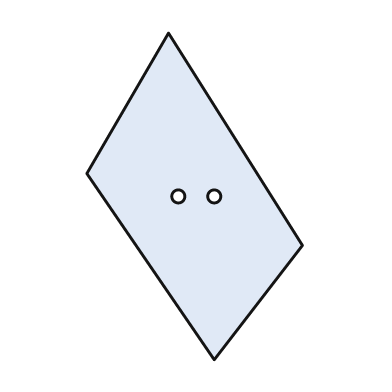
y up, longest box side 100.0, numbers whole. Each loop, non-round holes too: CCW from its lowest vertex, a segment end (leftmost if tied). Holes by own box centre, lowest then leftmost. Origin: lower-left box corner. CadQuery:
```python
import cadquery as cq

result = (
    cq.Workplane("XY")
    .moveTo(39.0, 0.0)
    .lineTo(66.0, 35.0)
    .lineTo(25.0, 100.0)
    .lineTo(0.0, 57.0)
    .close()
    .moveTo(28.0, 50.0)
    .circle(2.0)
    .moveTo(39.0, 50.0)
    .circle(2.0)
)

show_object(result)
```